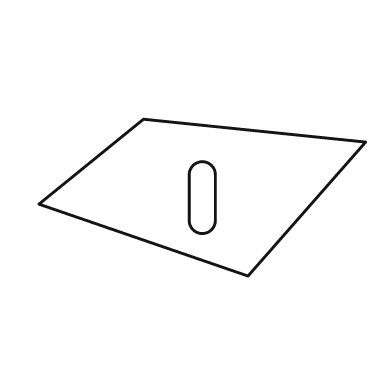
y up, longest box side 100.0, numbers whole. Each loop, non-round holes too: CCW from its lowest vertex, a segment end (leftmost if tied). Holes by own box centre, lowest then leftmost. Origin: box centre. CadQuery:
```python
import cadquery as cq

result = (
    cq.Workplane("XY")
    .moveTo(14.0, -24.0)
    .lineTo(50.0, 17.0)
    .lineTo(-18.0, 24.0)
    .lineTo(-50.0, -2.0)
    .close()
    .moveTo(-4.0, -7.0)
    .threePointArc((0.0, -11.0), (4.0, -7.0))
    .lineTo(4.0, 7.0)
    .threePointArc((0.0, 11.0), (-4.0, 7.0))
    .close()
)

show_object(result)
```